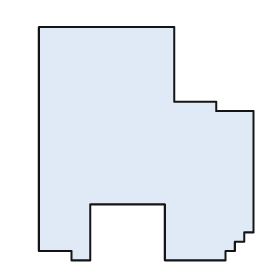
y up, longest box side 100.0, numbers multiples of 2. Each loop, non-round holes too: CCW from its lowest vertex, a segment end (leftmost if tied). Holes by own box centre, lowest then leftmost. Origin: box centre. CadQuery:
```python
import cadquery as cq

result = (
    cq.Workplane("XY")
    .moveTo(-32.0, -50.0)
    .lineTo(-24.0, -50.0)
    .lineTo(-24.0, -26.0)
    .lineTo(8.0, -26.0)
    .lineTo(8.0, -50.0)
    .lineTo(34.0, -50.0)
    .lineTo(34.0, -46.0)
    .lineTo(38.0, -46.0)
    .lineTo(38.0, -42.0)
    .lineTo(42.0, -42.0)
    .lineTo(42.0, -38.0)
    .lineTo(46.0, -38.0)
    .lineTo(46.0, 14.0)
    .lineTo(30.0, 14.0)
    .lineTo(30.0, 18.0)
    .lineTo(12.0, 18.0)
    .lineTo(12.0, 50.0)
    .lineTo(-46.0, 50.0)
    .lineTo(-46.0, -46.0)
    .lineTo(-32.0, -46.0)
    .close()
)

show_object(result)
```